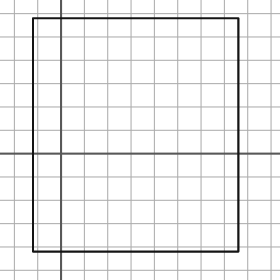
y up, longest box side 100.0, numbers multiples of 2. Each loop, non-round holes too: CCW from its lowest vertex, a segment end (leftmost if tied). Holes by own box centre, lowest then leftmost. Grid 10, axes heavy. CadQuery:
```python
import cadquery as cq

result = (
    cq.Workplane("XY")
    .moveTo(-12.0, -42.0)
    .lineTo(76.0, -42.0)
    .lineTo(76.0, 58.0)
    .lineTo(-12.0, 58.0)
    .close()
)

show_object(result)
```